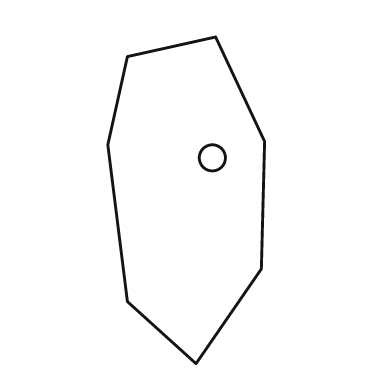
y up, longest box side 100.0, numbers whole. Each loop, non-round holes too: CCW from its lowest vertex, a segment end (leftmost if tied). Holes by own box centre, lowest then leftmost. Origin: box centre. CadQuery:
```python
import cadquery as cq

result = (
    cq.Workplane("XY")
    .moveTo(3.0, -50.0)
    .lineTo(23.0, -21.0)
    .lineTo(24.0, 18.0)
    .lineTo(9.0, 50.0)
    .lineTo(-18.0, 44.0)
    .lineTo(-24.0, 17.0)
    .lineTo(-18.0, -31.0)
    .close()
    .moveTo(8.0, 13.0)
    .circle(4.0)
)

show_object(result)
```